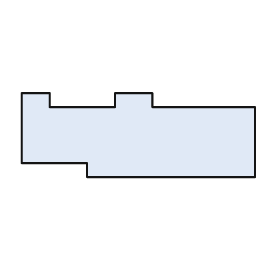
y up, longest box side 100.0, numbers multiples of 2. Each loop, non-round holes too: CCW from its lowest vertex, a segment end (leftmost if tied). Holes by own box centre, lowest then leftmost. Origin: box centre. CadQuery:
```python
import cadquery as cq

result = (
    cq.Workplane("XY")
    .moveTo(-22.0, -18.0)
    .lineTo(50.0, -18.0)
    .lineTo(50.0, 12.0)
    .lineTo(6.0, 12.0)
    .lineTo(6.0, 18.0)
    .lineTo(-10.0, 18.0)
    .lineTo(-10.0, 12.0)
    .lineTo(-38.0, 12.0)
    .lineTo(-38.0, 18.0)
    .lineTo(-50.0, 18.0)
    .lineTo(-50.0, -12.0)
    .lineTo(-22.0, -12.0)
    .close()
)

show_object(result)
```